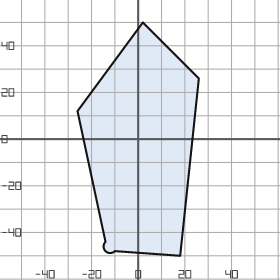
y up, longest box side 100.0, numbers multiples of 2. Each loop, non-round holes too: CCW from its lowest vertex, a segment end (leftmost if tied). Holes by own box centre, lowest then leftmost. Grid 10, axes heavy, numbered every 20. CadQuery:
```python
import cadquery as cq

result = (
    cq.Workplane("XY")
    .moveTo(18.0, -50.0)
    .lineTo(26.0, 26.0)
    .lineTo(2.0, 50.0)
    .lineTo(-26.0, 12.0)
    .lineTo(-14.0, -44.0)
    .threePointArc((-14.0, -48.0), (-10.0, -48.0))
    .close()
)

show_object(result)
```